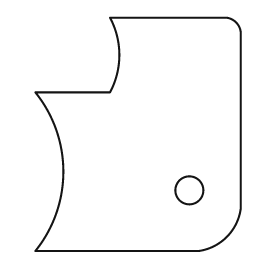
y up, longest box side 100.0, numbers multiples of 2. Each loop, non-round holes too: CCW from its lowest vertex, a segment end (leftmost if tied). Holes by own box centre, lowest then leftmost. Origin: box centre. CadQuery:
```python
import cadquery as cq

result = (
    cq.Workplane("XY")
    .moveTo(-44.0, -50.0)
    .lineTo(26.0, -50.0)
    .threePointArc((38.0, -44.0), (44.0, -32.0))
    .lineTo(44.0, 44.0)
    .threePointArc((42.0, 48.0), (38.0, 50.0))
    .lineTo(-12.0, 50.0)
    .threePointArc((-8.0, 34.0), (-12.0, 18.0))
    .lineTo(-44.0, 18.0)
    .threePointArc((-32.0, -16.0), (-44.0, -50.0))
    .close()
    .moveTo(22.0, -24.0)
    .circle(6.0)
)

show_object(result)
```